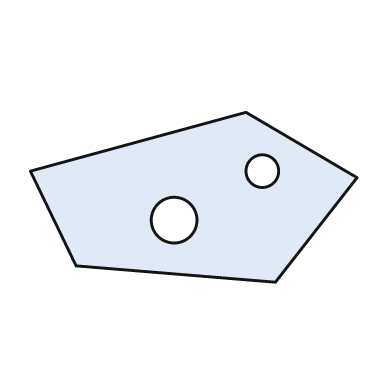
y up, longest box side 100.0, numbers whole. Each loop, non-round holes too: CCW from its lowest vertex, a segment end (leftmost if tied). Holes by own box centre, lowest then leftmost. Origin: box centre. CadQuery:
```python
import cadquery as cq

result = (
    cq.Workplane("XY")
    .moveTo(25.0, -26.0)
    .lineTo(50.0, 6.0)
    .lineTo(16.0, 26.0)
    .lineTo(-50.0, 8.0)
    .lineTo(-36.0, -21.0)
    .close()
    .moveTo(-6.0, -7.0)
    .circle(7.0)
    .moveTo(21.0, 8.0)
    .circle(5.0)
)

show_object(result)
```